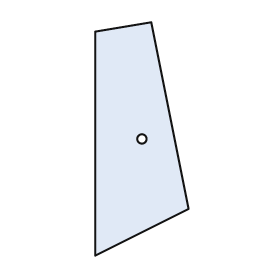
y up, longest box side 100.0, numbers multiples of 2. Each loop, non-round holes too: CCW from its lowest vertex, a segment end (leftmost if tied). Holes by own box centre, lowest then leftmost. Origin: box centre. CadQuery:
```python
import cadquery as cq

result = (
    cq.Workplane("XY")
    .moveTo(-20.0, -50.0)
    .lineTo(20.0, -30.0)
    .lineTo(4.0, 50.0)
    .lineTo(-20.0, 46.0)
    .close()
    .moveTo(0.0, 0.0)
    .circle(2.0)
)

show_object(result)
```